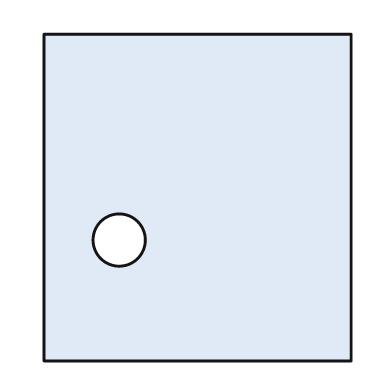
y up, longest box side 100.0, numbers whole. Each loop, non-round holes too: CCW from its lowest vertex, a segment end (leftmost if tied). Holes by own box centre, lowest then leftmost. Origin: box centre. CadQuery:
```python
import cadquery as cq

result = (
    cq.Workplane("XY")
    .moveTo(-47.0, -50.0)
    .lineTo(47.0, -50.0)
    .lineTo(47.0, 50.0)
    .lineTo(-47.0, 50.0)
    .close()
    .moveTo(-24.0, -13.0)
    .circle(8.0)
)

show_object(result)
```